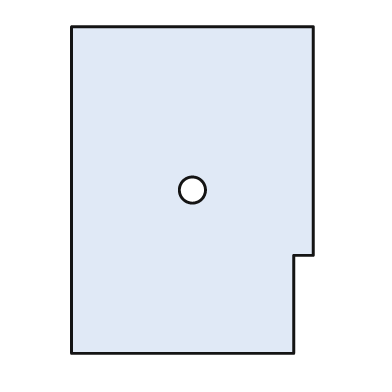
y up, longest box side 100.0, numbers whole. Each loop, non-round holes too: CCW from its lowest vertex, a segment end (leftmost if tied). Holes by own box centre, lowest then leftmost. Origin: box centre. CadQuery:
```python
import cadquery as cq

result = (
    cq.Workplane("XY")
    .moveTo(-37.0, -50.0)
    .lineTo(31.0, -50.0)
    .lineTo(31.0, -20.0)
    .lineTo(37.0, -20.0)
    .lineTo(37.0, 50.0)
    .lineTo(-37.0, 50.0)
    .close()
    .moveTo(0.0, 0.0)
    .circle(4.0)
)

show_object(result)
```